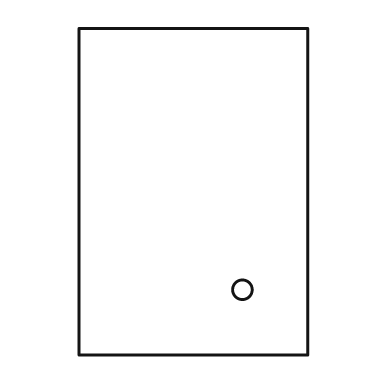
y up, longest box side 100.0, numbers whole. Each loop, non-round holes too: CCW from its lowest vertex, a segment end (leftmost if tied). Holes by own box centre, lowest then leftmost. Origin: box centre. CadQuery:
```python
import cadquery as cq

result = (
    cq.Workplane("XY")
    .moveTo(-35.0, -50.0)
    .lineTo(35.0, -50.0)
    .lineTo(35.0, 50.0)
    .lineTo(-35.0, 50.0)
    .close()
    .moveTo(15.0, -30.0)
    .circle(3.0)
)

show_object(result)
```